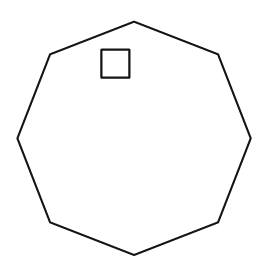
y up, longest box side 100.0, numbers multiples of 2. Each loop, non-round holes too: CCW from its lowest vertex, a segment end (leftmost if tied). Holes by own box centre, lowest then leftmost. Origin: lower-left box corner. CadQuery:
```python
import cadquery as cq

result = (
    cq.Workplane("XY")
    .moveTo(50.0, 0.0)
    .lineTo(86.0, 14.0)
    .lineTo(100.0, 50.0)
    .lineTo(86.0, 86.0)
    .lineTo(50.0, 100.0)
    .lineTo(14.0, 86.0)
    .lineTo(0.0, 50.0)
    .lineTo(14.0, 14.0)
    .close()
    .moveTo(36.0, 76.0)
    .lineTo(48.0, 76.0)
    .lineTo(48.0, 88.0)
    .lineTo(36.0, 88.0)
    .close()
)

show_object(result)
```